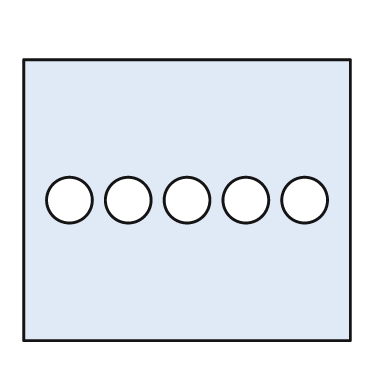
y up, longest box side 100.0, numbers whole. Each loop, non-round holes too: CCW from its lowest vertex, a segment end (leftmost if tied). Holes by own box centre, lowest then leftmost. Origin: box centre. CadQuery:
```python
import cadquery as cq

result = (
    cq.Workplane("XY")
    .moveTo(-50.0, -43.0)
    .lineTo(50.0, -43.0)
    .lineTo(50.0, 43.0)
    .lineTo(-50.0, 43.0)
    .close()
    .moveTo(-36.0, 0.0)
    .circle(7.0)
    .moveTo(-18.0, 0.0)
    .circle(7.0)
    .moveTo(0.0, 0.0)
    .circle(7.0)
    .moveTo(18.0, 0.0)
    .circle(7.0)
    .moveTo(36.0, 0.0)
    .circle(7.0)
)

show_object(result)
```